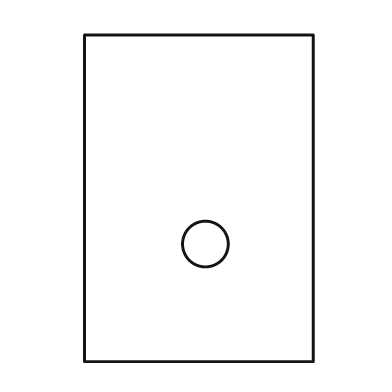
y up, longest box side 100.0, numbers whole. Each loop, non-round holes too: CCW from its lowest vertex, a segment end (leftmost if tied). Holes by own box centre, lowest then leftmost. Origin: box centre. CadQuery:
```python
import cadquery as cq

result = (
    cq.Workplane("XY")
    .moveTo(-35.0, -50.0)
    .lineTo(35.0, -50.0)
    .lineTo(35.0, 50.0)
    .lineTo(-35.0, 50.0)
    .close()
    .moveTo(2.0, -14.0)
    .circle(7.0)
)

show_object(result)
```